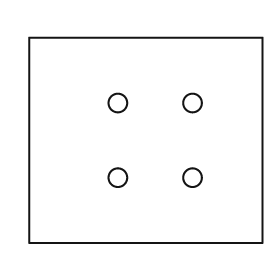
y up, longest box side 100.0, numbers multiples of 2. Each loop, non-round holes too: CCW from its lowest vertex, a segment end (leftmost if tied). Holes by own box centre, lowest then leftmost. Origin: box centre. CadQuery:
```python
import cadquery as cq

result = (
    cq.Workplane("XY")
    .moveTo(-50.0, -44.0)
    .lineTo(50.0, -44.0)
    .lineTo(50.0, 44.0)
    .lineTo(-50.0, 44.0)
    .close()
    .moveTo(-12.0, -16.0)
    .circle(4.0)
    .moveTo(20.0, -16.0)
    .circle(4.0)
    .moveTo(-12.0, 16.0)
    .circle(4.0)
    .moveTo(20.0, 16.0)
    .circle(4.0)
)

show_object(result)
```